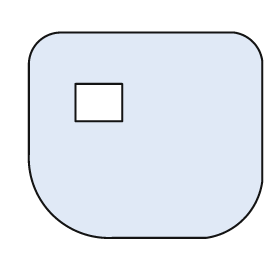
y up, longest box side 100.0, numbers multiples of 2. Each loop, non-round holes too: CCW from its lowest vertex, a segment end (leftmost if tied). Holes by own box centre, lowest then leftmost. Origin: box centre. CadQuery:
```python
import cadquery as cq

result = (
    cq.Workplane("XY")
    .moveTo(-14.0, -44.0)
    .lineTo(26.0, -44.0)
    .threePointArc((42.0, -36.0), (50.0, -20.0))
    .lineTo(50.0, 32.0)
    .threePointArc((46.0, 40.0), (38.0, 44.0))
    .lineTo(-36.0, 44.0)
    .threePointArc((-46.0, 40.0), (-50.0, 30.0))
    .lineTo(-50.0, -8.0)
    .threePointArc((-40.0, -34.0), (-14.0, -44.0))
    .close()
    .moveTo(-30.0, 6.0)
    .lineTo(-10.0, 6.0)
    .lineTo(-10.0, 22.0)
    .lineTo(-30.0, 22.0)
    .close()
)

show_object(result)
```